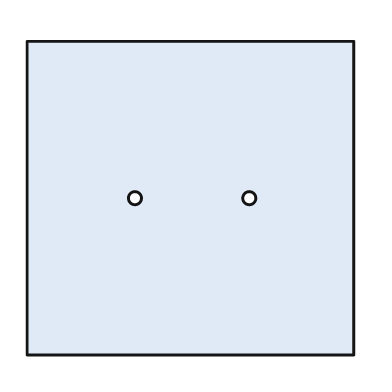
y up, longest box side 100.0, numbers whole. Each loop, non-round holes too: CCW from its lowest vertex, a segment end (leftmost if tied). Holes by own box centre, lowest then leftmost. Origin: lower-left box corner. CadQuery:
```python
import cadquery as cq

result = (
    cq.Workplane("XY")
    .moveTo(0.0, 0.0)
    .lineTo(100.0, 0.0)
    .lineTo(100.0, 96.0)
    .lineTo(0.0, 96.0)
    .close()
    .moveTo(33.0, 48.0)
    .circle(2.0)
    .moveTo(68.0, 48.0)
    .circle(2.0)
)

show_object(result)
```